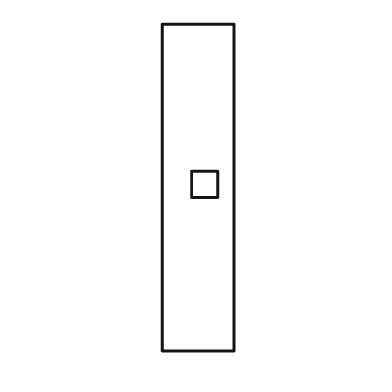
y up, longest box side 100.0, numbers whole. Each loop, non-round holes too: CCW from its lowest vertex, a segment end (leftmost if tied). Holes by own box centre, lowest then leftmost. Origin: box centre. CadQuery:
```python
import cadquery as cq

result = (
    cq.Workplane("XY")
    .moveTo(-11.0, -50.0)
    .lineTo(11.0, -50.0)
    .lineTo(11.0, 50.0)
    .lineTo(-11.0, 50.0)
    .close()
    .moveTo(-2.0, -3.0)
    .lineTo(6.0, -3.0)
    .lineTo(6.0, 5.0)
    .lineTo(-2.0, 5.0)
    .close()
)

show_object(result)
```